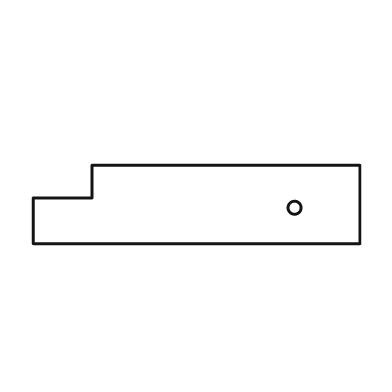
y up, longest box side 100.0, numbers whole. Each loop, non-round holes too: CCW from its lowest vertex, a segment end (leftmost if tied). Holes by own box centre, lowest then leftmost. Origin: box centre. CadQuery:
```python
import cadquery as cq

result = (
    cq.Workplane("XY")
    .moveTo(-50.0, -12.0)
    .lineTo(50.0, -12.0)
    .lineTo(50.0, 12.0)
    .lineTo(-32.0, 12.0)
    .lineTo(-32.0, 2.0)
    .lineTo(-50.0, 2.0)
    .close()
    .moveTo(30.0, -1.0)
    .circle(2.0)
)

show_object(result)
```